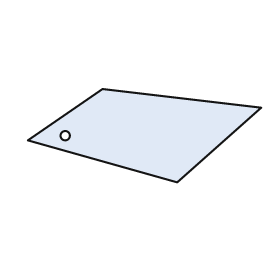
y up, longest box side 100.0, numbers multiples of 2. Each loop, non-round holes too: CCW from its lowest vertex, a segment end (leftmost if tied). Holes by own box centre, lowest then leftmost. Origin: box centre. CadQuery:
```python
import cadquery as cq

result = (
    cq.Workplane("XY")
    .moveTo(14.0, -20.0)
    .lineTo(50.0, 12.0)
    .lineTo(-18.0, 20.0)
    .lineTo(-50.0, -2.0)
    .close()
    .moveTo(-34.0, 0.0)
    .circle(2.0)
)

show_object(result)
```